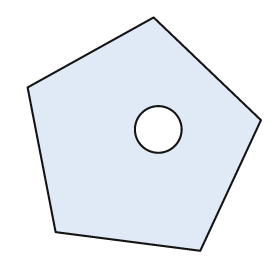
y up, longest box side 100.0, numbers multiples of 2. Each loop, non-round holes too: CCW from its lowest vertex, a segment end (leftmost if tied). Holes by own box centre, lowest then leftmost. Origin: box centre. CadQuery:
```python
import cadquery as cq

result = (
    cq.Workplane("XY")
    .moveTo(24.0, -50.0)
    .lineTo(50.0, 6.0)
    .lineTo(4.0, 50.0)
    .lineTo(-50.0, 20.0)
    .lineTo(-38.0, -42.0)
    .close()
    .moveTo(6.0, 2.0)
    .circle(10.0)
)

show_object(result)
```